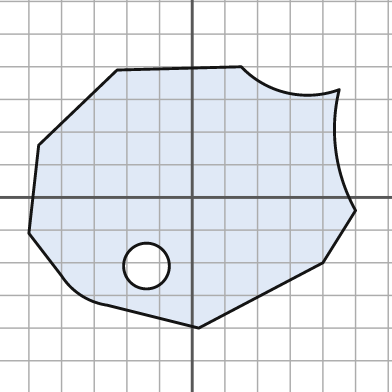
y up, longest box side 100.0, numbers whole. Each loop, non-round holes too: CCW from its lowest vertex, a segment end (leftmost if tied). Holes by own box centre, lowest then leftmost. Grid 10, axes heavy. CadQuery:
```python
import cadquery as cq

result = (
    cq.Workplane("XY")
    .moveTo(2.0, -40.0)
    .lineTo(40.0, -20.0)
    .lineTo(50.0, -4.0)
    .threePointArc((44.0, 14.0), (45.0, 33.0))
    .threePointArc((29.0, 32.0), (15.0, 40.0))
    .lineTo(-23.0, 39.0)
    .lineTo(-47.0, 16.0)
    .lineTo(-50.0, -11.0)
    .lineTo(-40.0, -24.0)
    .threePointArc((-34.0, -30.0), (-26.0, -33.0))
    .close()
    .moveTo(-14.0, -21.0)
    .circle(7.0)
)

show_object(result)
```